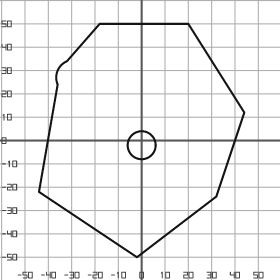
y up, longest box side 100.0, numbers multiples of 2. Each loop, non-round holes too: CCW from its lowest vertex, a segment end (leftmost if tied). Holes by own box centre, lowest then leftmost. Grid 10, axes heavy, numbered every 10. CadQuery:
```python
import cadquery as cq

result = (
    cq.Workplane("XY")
    .moveTo(-2.0, -50.0)
    .lineTo(32.0, -24.0)
    .lineTo(44.0, 12.0)
    .lineTo(20.0, 50.0)
    .lineTo(-18.0, 50.0)
    .lineTo(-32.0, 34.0)
    .threePointArc((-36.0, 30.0), (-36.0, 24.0))
    .lineTo(-44.0, -22.0)
    .close()
    .moveTo(0.0, -2.0)
    .circle(6.0)
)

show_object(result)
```